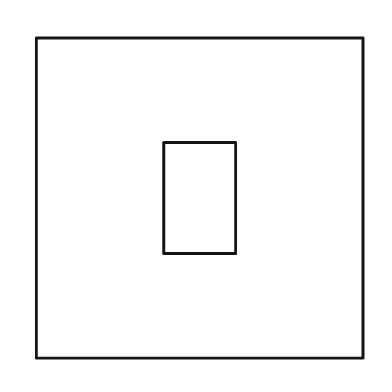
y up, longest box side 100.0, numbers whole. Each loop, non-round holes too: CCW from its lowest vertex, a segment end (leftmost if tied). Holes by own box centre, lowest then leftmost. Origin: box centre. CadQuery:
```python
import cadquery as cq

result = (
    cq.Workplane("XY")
    .moveTo(-50.0, -49.0)
    .lineTo(50.0, -49.0)
    .lineTo(50.0, 49.0)
    .lineTo(-50.0, 49.0)
    .close()
    .moveTo(-11.0, -17.0)
    .lineTo(11.0, -17.0)
    .lineTo(11.0, 17.0)
    .lineTo(-11.0, 17.0)
    .close()
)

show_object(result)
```